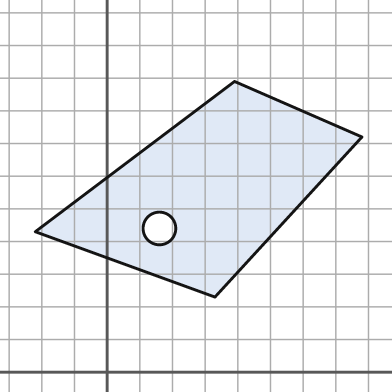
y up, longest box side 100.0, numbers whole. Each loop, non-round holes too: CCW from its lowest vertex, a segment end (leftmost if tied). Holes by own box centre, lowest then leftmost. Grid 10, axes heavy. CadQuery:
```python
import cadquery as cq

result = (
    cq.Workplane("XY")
    .moveTo(33.0, 23.0)
    .lineTo(78.0, 72.0)
    .lineTo(39.0, 89.0)
    .lineTo(-22.0, 43.0)
    .close()
    .moveTo(16.0, 44.0)
    .circle(5.0)
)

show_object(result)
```